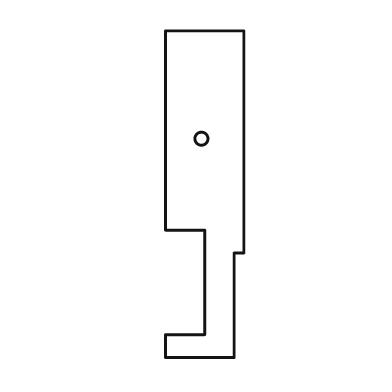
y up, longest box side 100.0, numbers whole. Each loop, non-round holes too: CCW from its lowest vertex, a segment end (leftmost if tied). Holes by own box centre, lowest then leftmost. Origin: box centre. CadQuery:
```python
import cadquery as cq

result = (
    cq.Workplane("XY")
    .moveTo(-12.0, -50.0)
    .lineTo(9.0, -50.0)
    .lineTo(9.0, -18.0)
    .lineTo(12.0, -18.0)
    .lineTo(12.0, 50.0)
    .lineTo(-12.0, 50.0)
    .lineTo(-12.0, -11.0)
    .lineTo(0.0, -11.0)
    .lineTo(0.0, -43.0)
    .lineTo(-12.0, -43.0)
    .close()
    .moveTo(-1.0, 17.0)
    .circle(2.0)
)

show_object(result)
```